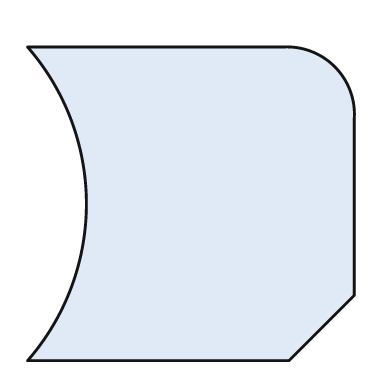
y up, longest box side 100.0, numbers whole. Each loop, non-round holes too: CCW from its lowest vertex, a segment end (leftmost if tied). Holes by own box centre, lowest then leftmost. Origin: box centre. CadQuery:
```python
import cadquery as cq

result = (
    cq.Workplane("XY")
    .moveTo(-50.0, -48.0)
    .lineTo(30.0, -48.0)
    .lineTo(50.0, -28.0)
    .lineTo(50.0, 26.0)
    .threePointArc((44.0, 42.0), (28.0, 48.0))
    .lineTo(-50.0, 48.0)
    .threePointArc((-32.0, 0.0), (-50.0, -48.0))
    .close()
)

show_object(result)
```